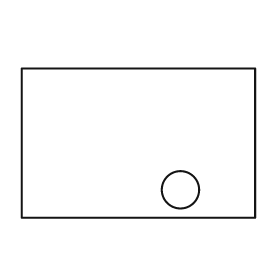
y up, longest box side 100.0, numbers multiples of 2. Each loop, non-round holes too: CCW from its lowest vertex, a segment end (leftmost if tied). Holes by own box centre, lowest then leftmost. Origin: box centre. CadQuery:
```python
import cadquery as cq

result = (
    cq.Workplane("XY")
    .moveTo(-50.0, -32.0)
    .lineTo(50.0, -32.0)
    .lineTo(50.0, 32.0)
    .lineTo(-50.0, 32.0)
    .close()
    .moveTo(18.0, -20.0)
    .circle(8.0)
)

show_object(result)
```